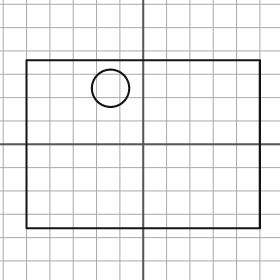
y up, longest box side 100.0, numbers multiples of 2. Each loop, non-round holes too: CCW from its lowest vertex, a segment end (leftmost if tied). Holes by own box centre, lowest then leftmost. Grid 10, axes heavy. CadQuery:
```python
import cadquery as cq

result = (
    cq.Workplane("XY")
    .moveTo(-50.0, -36.0)
    .lineTo(50.0, -36.0)
    .lineTo(50.0, 36.0)
    .lineTo(-50.0, 36.0)
    .close()
    .moveTo(-14.0, 24.0)
    .circle(8.0)
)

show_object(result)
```